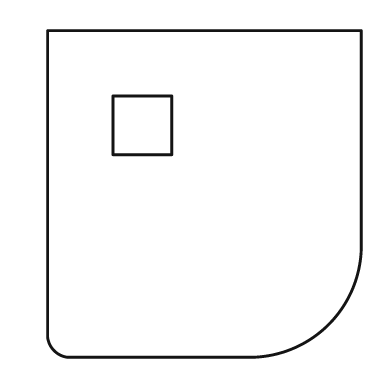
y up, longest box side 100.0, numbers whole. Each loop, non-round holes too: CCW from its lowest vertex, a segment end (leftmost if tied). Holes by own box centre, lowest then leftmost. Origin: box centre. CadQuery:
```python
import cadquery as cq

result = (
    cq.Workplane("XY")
    .moveTo(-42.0, -50.0)
    .lineTo(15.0, -50.0)
    .threePointArc((38.0, -40.0), (48.0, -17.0))
    .lineTo(48.0, 50.0)
    .lineTo(-48.0, 50.0)
    .lineTo(-48.0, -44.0)
    .threePointArc((-46.0, -48.0), (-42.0, -50.0))
    .close()
    .moveTo(-28.0, 12.0)
    .lineTo(-10.0, 12.0)
    .lineTo(-10.0, 30.0)
    .lineTo(-28.0, 30.0)
    .close()
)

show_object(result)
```